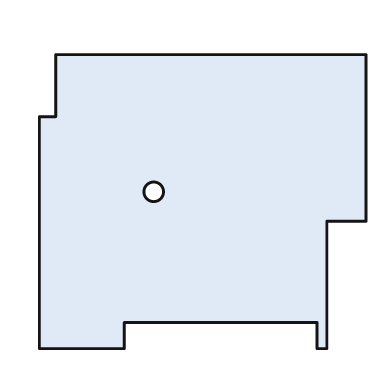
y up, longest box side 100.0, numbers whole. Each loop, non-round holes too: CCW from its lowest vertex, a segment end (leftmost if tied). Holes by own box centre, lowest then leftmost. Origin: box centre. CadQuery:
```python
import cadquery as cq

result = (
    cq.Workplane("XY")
    .moveTo(-50.0, -45.0)
    .lineTo(-24.0, -45.0)
    .lineTo(-24.0, -37.0)
    .lineTo(35.0, -37.0)
    .lineTo(35.0, -45.0)
    .lineTo(38.0, -45.0)
    .lineTo(38.0, -6.0)
    .lineTo(50.0, -6.0)
    .lineTo(50.0, 45.0)
    .lineTo(-45.0, 45.0)
    .lineTo(-45.0, 26.0)
    .lineTo(-50.0, 26.0)
    .close()
    .moveTo(-15.0, 3.0)
    .circle(3.0)
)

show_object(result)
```